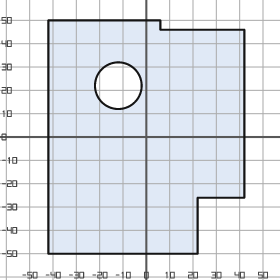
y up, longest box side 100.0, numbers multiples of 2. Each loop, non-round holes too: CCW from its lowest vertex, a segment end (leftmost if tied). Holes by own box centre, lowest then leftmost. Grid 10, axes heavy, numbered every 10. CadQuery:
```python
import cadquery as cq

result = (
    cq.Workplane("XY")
    .moveTo(-42.0, -50.0)
    .lineTo(22.0, -50.0)
    .lineTo(22.0, -26.0)
    .lineTo(42.0, -26.0)
    .lineTo(42.0, 46.0)
    .lineTo(6.0, 46.0)
    .lineTo(6.0, 50.0)
    .lineTo(-42.0, 50.0)
    .close()
    .moveTo(-12.0, 22.0)
    .circle(10.0)
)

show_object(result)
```